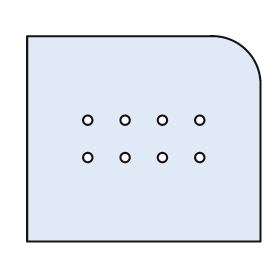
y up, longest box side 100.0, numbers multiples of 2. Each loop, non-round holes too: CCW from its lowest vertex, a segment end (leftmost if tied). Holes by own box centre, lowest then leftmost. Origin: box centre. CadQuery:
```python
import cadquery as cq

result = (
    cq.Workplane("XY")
    .moveTo(-50.0, -44.0)
    .lineTo(50.0, -44.0)
    .lineTo(50.0, 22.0)
    .threePointArc((44.0, 38.0), (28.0, 44.0))
    .lineTo(-50.0, 44.0)
    .close()
    .moveTo(-24.0, -8.0)
    .circle(2.0)
    .moveTo(-8.0, -8.0)
    .circle(2.0)
    .moveTo(8.0, -8.0)
    .circle(2.0)
    .moveTo(24.0, -8.0)
    .circle(2.0)
    .moveTo(-24.0, 8.0)
    .circle(2.0)
    .moveTo(-8.0, 8.0)
    .circle(2.0)
    .moveTo(8.0, 8.0)
    .circle(2.0)
    .moveTo(24.0, 8.0)
    .circle(2.0)
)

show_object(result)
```